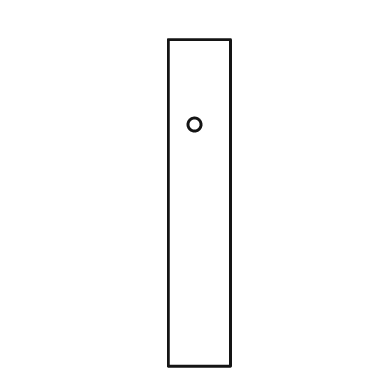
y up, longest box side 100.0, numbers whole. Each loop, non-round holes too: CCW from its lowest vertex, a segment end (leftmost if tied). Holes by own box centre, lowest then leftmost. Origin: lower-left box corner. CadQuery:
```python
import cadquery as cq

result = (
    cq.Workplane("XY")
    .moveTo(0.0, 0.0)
    .lineTo(19.0, 0.0)
    .lineTo(19.0, 100.0)
    .lineTo(0.0, 100.0)
    .close()
    .moveTo(8.0, 74.0)
    .circle(2.0)
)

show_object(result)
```